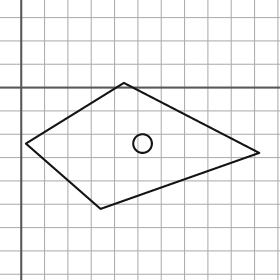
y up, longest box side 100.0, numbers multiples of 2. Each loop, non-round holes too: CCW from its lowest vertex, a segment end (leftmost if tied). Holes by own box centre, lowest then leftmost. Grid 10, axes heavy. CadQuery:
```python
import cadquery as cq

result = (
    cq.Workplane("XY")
    .moveTo(34.0, -52.0)
    .lineTo(102.0, -28.0)
    .lineTo(44.0, 2.0)
    .lineTo(2.0, -24.0)
    .close()
    .moveTo(52.0, -24.0)
    .circle(4.0)
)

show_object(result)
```